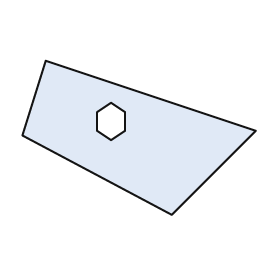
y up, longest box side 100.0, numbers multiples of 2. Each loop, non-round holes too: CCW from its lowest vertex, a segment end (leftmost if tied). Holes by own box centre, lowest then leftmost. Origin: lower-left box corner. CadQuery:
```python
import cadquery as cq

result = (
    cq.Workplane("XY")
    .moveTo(64.0, 0.0)
    .lineTo(100.0, 36.0)
    .lineTo(10.0, 66.0)
    .lineTo(0.0, 34.0)
    .close()
    .moveTo(38.0, 32.0)
    .lineTo(44.0, 36.0)
    .lineTo(44.0, 44.0)
    .lineTo(38.0, 48.0)
    .lineTo(32.0, 44.0)
    .lineTo(32.0, 36.0)
    .close()
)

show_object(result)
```